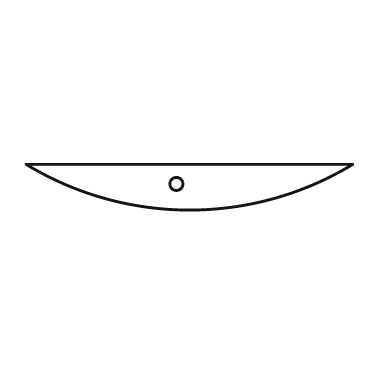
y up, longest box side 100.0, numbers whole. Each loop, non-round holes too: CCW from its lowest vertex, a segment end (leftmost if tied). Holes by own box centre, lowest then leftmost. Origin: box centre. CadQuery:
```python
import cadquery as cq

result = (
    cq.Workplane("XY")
    .moveTo(-50.0, 7.0)
    .threePointArc((0.0, -7.0), (50.0, 7.0))
    .close()
    .moveTo(-4.0, 1.0)
    .circle(2.0)
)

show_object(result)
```